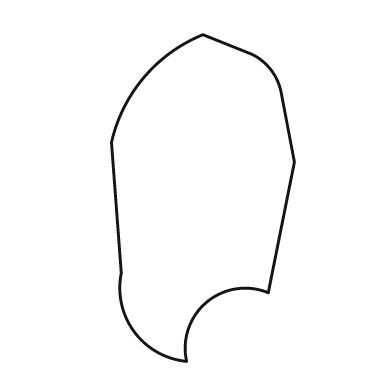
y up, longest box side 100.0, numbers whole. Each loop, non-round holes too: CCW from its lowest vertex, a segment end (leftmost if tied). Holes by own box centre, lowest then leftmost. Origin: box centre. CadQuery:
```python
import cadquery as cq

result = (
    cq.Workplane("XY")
    .moveTo(-5.0, -50.0)
    .threePointArc((1.0, -32.0), (20.0, -29.0))
    .lineTo(28.0, 11.0)
    .lineTo(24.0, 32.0)
    .threePointArc((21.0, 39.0), (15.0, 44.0))
    .lineTo(0.0, 50.0)
    .threePointArc((-18.0, 37.0), (-28.0, 17.0))
    .lineTo(-25.0, -23.0)
    .threePointArc((-21.0, -41.0), (-5.0, -50.0))
    .close()
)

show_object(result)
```